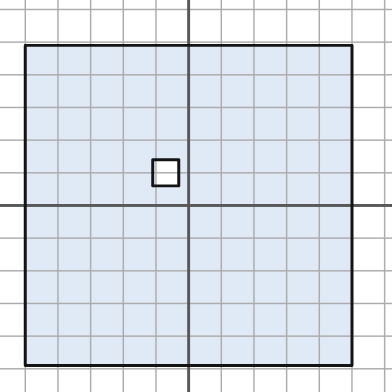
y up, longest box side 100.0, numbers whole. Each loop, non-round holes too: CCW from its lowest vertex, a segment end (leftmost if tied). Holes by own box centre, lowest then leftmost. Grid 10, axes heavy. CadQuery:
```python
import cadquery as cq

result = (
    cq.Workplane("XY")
    .moveTo(-50.0, -49.0)
    .lineTo(50.0, -49.0)
    .lineTo(50.0, 49.0)
    .lineTo(-50.0, 49.0)
    .close()
    .moveTo(-11.0, 6.0)
    .lineTo(-3.0, 6.0)
    .lineTo(-3.0, 14.0)
    .lineTo(-11.0, 14.0)
    .close()
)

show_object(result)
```